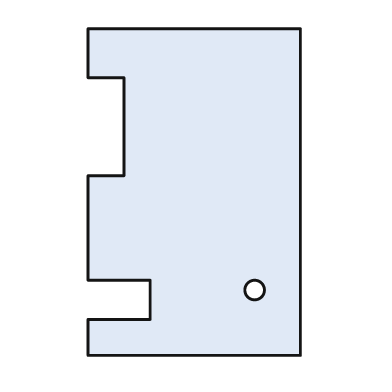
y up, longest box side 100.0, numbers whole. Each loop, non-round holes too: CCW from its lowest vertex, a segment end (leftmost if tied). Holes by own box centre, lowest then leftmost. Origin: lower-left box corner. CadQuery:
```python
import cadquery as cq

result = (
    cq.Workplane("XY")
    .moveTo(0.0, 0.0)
    .lineTo(65.0, 0.0)
    .lineTo(65.0, 100.0)
    .lineTo(0.0, 100.0)
    .lineTo(0.0, 85.0)
    .lineTo(11.0, 85.0)
    .lineTo(11.0, 55.0)
    .lineTo(0.0, 55.0)
    .lineTo(0.0, 23.0)
    .lineTo(19.0, 23.0)
    .lineTo(19.0, 11.0)
    .lineTo(0.0, 11.0)
    .close()
    .moveTo(51.0, 20.0)
    .circle(3.0)
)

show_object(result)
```